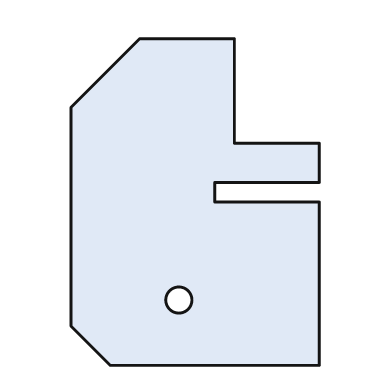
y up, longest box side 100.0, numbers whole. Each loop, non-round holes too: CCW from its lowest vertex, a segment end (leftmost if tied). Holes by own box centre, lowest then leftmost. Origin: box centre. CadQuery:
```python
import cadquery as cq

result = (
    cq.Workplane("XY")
    .moveTo(-26.0, -50.0)
    .lineTo(38.0, -50.0)
    .lineTo(38.0, 0.0)
    .lineTo(6.0, 0.0)
    .lineTo(6.0, 6.0)
    .lineTo(38.0, 6.0)
    .lineTo(38.0, 18.0)
    .lineTo(12.0, 18.0)
    .lineTo(12.0, 50.0)
    .lineTo(-17.0, 50.0)
    .lineTo(-38.0, 29.0)
    .lineTo(-38.0, -38.0)
    .close()
    .moveTo(-5.0, -30.0)
    .circle(4.0)
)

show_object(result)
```